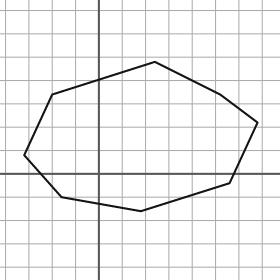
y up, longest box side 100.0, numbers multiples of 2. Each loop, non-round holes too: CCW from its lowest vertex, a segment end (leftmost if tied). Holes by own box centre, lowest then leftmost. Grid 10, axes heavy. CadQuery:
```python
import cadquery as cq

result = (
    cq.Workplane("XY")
    .moveTo(18.0, -16.0)
    .lineTo(56.0, -4.0)
    .lineTo(68.0, 22.0)
    .lineTo(52.0, 34.0)
    .lineTo(24.0, 48.0)
    .lineTo(-20.0, 34.0)
    .lineTo(-32.0, 8.0)
    .lineTo(-16.0, -10.0)
    .close()
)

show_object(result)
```